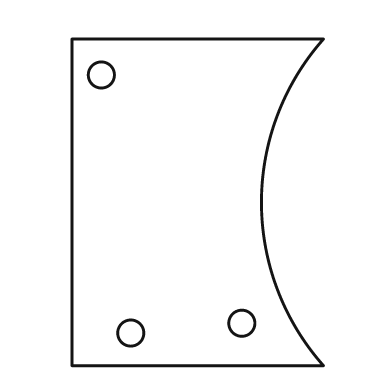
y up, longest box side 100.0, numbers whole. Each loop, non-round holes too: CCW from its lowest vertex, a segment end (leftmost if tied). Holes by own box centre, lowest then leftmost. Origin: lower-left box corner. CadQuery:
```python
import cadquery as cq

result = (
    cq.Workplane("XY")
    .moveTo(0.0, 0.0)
    .lineTo(77.0, 0.0)
    .threePointArc((58.0, 50.0), (77.0, 100.0))
    .lineTo(0.0, 100.0)
    .close()
    .moveTo(18.0, 10.0)
    .circle(4.0)
    .moveTo(52.0, 13.0)
    .circle(4.0)
    .moveTo(9.0, 89.0)
    .circle(4.0)
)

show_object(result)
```